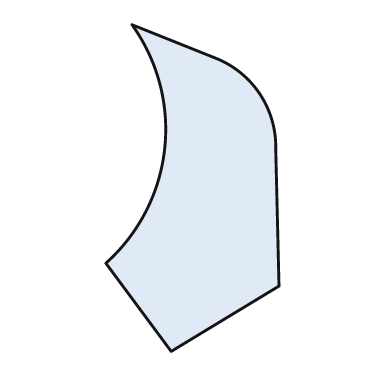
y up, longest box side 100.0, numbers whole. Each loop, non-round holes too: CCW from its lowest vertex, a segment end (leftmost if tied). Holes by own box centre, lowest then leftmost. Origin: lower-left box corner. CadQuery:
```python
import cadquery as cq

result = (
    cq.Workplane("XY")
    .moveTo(20.0, 0.0)
    .lineTo(53.0, 20.0)
    .lineTo(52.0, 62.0)
    .threePointArc((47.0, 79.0), (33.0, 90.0))
    .lineTo(8.0, 100.0)
    .threePointArc((18.0, 62.0), (0.0, 27.0))
    .close()
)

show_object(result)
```